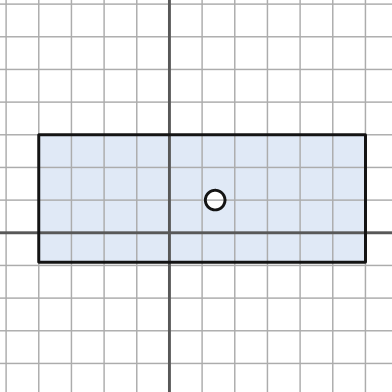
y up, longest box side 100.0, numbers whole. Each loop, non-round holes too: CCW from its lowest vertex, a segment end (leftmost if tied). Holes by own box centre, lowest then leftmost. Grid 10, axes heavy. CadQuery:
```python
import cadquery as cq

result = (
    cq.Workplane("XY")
    .moveTo(-40.0, -9.0)
    .lineTo(60.0, -9.0)
    .lineTo(60.0, 30.0)
    .lineTo(-40.0, 30.0)
    .close()
    .moveTo(14.0, 10.0)
    .circle(3.0)
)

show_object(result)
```